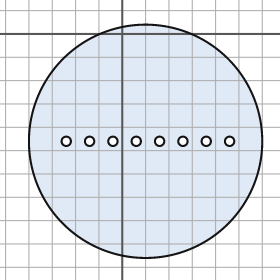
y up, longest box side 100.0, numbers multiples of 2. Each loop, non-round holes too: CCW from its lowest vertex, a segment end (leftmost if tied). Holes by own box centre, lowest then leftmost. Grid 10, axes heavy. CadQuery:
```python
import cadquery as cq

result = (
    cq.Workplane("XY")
    .moveTo(10.0, -46.0)
    .circle(50.0)
    .moveTo(-24.0, -46.0)
    .circle(2.0)
    .moveTo(-14.0, -46.0)
    .circle(2.0)
    .moveTo(-4.0, -46.0)
    .circle(2.0)
    .moveTo(6.0, -46.0)
    .circle(2.0)
    .moveTo(16.0, -46.0)
    .circle(2.0)
    .moveTo(26.0, -46.0)
    .circle(2.0)
    .moveTo(36.0, -46.0)
    .circle(2.0)
    .moveTo(46.0, -46.0)
    .circle(2.0)
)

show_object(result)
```